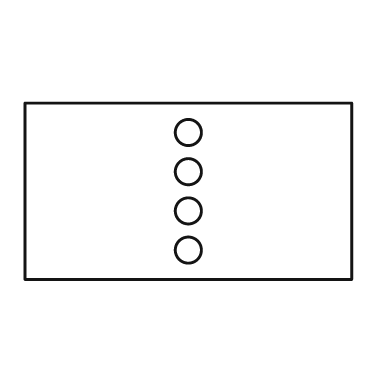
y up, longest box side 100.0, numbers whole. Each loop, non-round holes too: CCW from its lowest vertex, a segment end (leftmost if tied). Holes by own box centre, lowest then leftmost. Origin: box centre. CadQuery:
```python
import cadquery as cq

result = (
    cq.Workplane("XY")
    .moveTo(-50.0, -27.0)
    .lineTo(50.0, -27.0)
    .lineTo(50.0, 27.0)
    .lineTo(-50.0, 27.0)
    .close()
    .moveTo(0.0, -18.0)
    .circle(4.0)
    .moveTo(0.0, -6.0)
    .circle(4.0)
    .moveTo(0.0, 6.0)
    .circle(4.0)
    .moveTo(0.0, 18.0)
    .circle(4.0)
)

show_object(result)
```